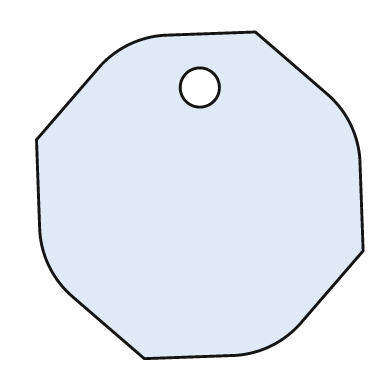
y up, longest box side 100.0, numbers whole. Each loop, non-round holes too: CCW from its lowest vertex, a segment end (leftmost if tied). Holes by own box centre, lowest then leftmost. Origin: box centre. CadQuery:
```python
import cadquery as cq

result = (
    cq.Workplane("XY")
    .moveTo(-17.0, -50.0)
    .lineTo(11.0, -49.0)
    .threePointArc((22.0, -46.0), (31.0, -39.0))
    .lineTo(50.0, -17.0)
    .lineTo(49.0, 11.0)
    .threePointArc((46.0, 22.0), (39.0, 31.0))
    .lineTo(17.0, 50.0)
    .lineTo(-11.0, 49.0)
    .threePointArc((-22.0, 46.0), (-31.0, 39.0))
    .lineTo(-50.0, 17.0)
    .lineTo(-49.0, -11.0)
    .threePointArc((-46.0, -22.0), (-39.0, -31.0))
    .close()
    .moveTo(0.0, 33.0)
    .circle(6.0)
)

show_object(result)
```